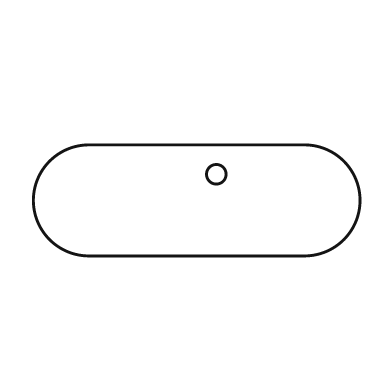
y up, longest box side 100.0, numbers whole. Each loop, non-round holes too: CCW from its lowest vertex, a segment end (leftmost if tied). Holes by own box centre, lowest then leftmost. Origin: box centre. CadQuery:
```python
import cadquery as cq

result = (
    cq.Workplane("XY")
    .moveTo(-33.0, -17.0)
    .lineTo(33.0, -17.0)
    .threePointArc((50.0, 0.0), (33.0, 17.0))
    .lineTo(-33.0, 17.0)
    .threePointArc((-50.0, 0.0), (-33.0, -17.0))
    .close()
    .moveTo(6.0, 8.0)
    .circle(3.0)
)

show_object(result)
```